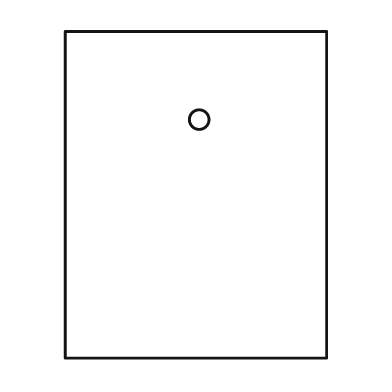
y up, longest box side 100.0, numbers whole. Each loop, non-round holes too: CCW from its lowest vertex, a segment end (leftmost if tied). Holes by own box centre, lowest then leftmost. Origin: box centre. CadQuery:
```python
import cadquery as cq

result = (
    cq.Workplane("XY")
    .moveTo(-40.0, -50.0)
    .lineTo(40.0, -50.0)
    .lineTo(40.0, 50.0)
    .lineTo(-40.0, 50.0)
    .close()
    .moveTo(1.0, 23.0)
    .circle(3.0)
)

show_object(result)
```